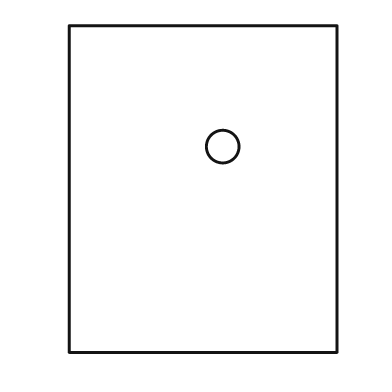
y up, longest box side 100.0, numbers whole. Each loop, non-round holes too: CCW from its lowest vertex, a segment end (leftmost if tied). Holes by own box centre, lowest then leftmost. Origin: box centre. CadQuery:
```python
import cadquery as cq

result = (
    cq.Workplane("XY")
    .moveTo(-41.0, -50.0)
    .lineTo(41.0, -50.0)
    .lineTo(41.0, 50.0)
    .lineTo(-41.0, 50.0)
    .close()
    .moveTo(6.0, 13.0)
    .circle(5.0)
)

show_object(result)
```